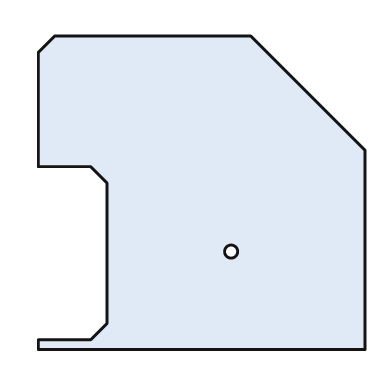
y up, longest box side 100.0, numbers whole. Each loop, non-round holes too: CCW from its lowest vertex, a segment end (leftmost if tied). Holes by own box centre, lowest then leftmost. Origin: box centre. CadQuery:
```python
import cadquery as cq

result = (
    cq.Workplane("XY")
    .moveTo(-50.0, -48.0)
    .lineTo(50.0, -48.0)
    .lineTo(50.0, 13.0)
    .lineTo(15.0, 48.0)
    .lineTo(-45.0, 48.0)
    .lineTo(-50.0, 43.0)
    .lineTo(-50.0, 8.0)
    .lineTo(-34.0, 8.0)
    .lineTo(-29.0, 3.0)
    .lineTo(-29.0, -40.0)
    .lineTo(-34.0, -45.0)
    .lineTo(-50.0, -45.0)
    .close()
    .moveTo(9.0, -18.0)
    .circle(2.0)
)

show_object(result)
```